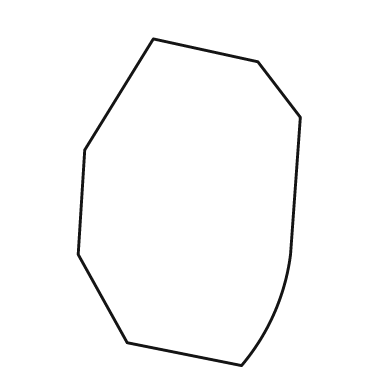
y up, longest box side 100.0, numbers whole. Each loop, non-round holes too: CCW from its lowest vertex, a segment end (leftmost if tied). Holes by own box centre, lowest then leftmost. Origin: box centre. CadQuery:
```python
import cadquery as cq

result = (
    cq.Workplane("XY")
    .moveTo(16.0, -50.0)
    .threePointArc((26.0, -34.0), (31.0, -16.0))
    .lineTo(34.0, 26.0)
    .lineTo(21.0, 43.0)
    .lineTo(-11.0, 50.0)
    .lineTo(-32.0, 16.0)
    .lineTo(-34.0, -16.0)
    .lineTo(-19.0, -43.0)
    .close()
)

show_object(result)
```